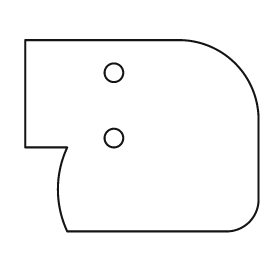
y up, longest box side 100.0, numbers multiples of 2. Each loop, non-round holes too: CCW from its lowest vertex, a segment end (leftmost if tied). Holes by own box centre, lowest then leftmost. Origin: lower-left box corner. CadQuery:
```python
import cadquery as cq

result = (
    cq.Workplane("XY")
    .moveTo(18.0, 0.0)
    .lineTo(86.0, 0.0)
    .threePointArc((96.0, 4.0), (100.0, 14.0))
    .lineTo(100.0, 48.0)
    .threePointArc((90.0, 72.0), (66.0, 82.0))
    .lineTo(0.0, 82.0)
    .lineTo(0.0, 36.0)
    .lineTo(18.0, 36.0)
    .threePointArc((14.0, 18.0), (18.0, 0.0))
    .close()
    .moveTo(38.0, 40.0)
    .circle(4.0)
    .moveTo(38.0, 68.0)
    .circle(4.0)
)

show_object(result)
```